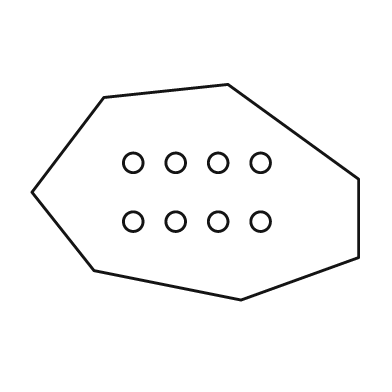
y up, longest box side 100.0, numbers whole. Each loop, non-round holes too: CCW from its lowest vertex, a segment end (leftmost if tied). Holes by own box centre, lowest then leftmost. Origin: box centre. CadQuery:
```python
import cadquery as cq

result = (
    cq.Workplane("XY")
    .moveTo(14.0, -33.0)
    .lineTo(50.0, -20.0)
    .lineTo(50.0, 4.0)
    .lineTo(10.0, 33.0)
    .lineTo(-28.0, 29.0)
    .lineTo(-50.0, 0.0)
    .lineTo(-31.0, -24.0)
    .close()
    .moveTo(-19.0, -9.0)
    .circle(3.0)
    .moveTo(-6.0, -9.0)
    .circle(3.0)
    .moveTo(7.0, -9.0)
    .circle(3.0)
    .moveTo(20.0, -9.0)
    .circle(3.0)
    .moveTo(-19.0, 9.0)
    .circle(3.0)
    .moveTo(-6.0, 9.0)
    .circle(3.0)
    .moveTo(7.0, 9.0)
    .circle(3.0)
    .moveTo(20.0, 9.0)
    .circle(3.0)
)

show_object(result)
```